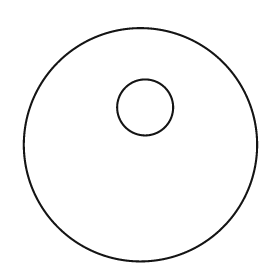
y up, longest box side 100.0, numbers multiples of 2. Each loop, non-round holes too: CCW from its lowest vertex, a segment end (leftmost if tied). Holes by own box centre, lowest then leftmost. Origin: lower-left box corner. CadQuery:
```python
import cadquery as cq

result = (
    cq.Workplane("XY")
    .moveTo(50.0, 50.0)
    .circle(50.0)
    .moveTo(52.0, 66.0)
    .circle(12.0)
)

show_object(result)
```